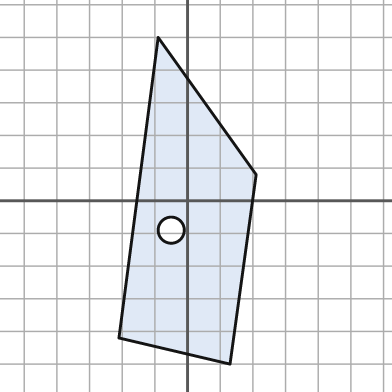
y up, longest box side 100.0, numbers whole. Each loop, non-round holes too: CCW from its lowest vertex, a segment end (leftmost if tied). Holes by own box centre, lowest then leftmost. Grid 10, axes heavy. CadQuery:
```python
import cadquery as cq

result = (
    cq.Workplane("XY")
    .moveTo(13.0, -50.0)
    .lineTo(21.0, 8.0)
    .lineTo(-9.0, 50.0)
    .lineTo(-21.0, -42.0)
    .close()
    .moveTo(-5.0, -9.0)
    .circle(4.0)
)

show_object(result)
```